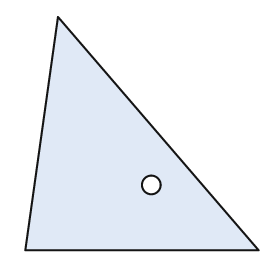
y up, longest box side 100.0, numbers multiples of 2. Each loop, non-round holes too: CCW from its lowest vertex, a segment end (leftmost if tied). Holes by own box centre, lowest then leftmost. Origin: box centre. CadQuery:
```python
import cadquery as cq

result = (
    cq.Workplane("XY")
    .moveTo(-50.0, -50.0)
    .lineTo(50.0, -50.0)
    .lineTo(-36.0, 50.0)
    .close()
    .moveTo(4.0, -22.0)
    .circle(4.0)
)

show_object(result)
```